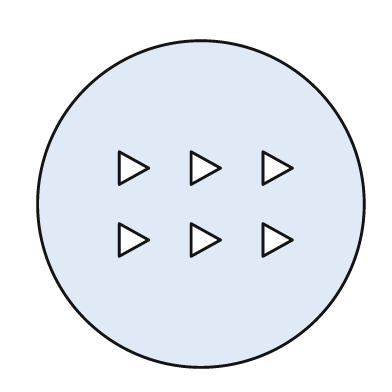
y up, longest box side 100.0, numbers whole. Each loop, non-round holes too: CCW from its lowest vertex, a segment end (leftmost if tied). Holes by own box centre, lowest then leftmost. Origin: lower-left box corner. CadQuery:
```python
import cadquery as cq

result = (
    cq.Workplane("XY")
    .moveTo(50.0, 50.0)
    .circle(50.0)
    .moveTo(25.0, 34.0)
    .lineTo(34.0, 39.0)
    .lineTo(25.0, 44.0)
    .close()
    .moveTo(47.0, 34.0)
    .lineTo(56.0, 39.0)
    .lineTo(47.0, 44.0)
    .close()
    .moveTo(69.0, 34.0)
    .lineTo(78.0, 39.0)
    .lineTo(69.0, 44.0)
    .close()
    .moveTo(25.0, 56.0)
    .lineTo(34.0, 61.0)
    .lineTo(25.0, 66.0)
    .close()
    .moveTo(47.0, 56.0)
    .lineTo(56.0, 61.0)
    .lineTo(47.0, 66.0)
    .close()
    .moveTo(69.0, 56.0)
    .lineTo(78.0, 61.0)
    .lineTo(69.0, 66.0)
    .close()
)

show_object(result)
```